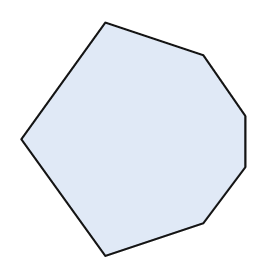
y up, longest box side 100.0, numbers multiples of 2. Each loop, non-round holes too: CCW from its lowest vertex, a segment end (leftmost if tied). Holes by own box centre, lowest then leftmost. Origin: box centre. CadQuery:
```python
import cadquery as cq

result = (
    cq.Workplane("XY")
    .moveTo(-12.0, -50.0)
    .lineTo(30.0, -36.0)
    .lineTo(48.0, -12.0)
    .lineTo(48.0, 10.0)
    .lineTo(30.0, 36.0)
    .lineTo(-12.0, 50.0)
    .lineTo(-48.0, 0.0)
    .close()
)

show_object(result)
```